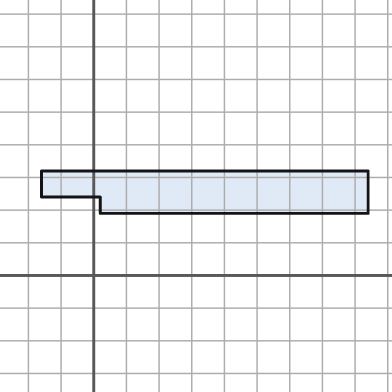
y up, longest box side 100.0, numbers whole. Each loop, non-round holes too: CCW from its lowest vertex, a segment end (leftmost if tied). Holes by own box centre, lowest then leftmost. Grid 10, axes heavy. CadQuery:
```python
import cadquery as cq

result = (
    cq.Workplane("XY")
    .moveTo(2.0, 19.0)
    .lineTo(84.0, 19.0)
    .lineTo(84.0, 32.0)
    .lineTo(-16.0, 32.0)
    .lineTo(-16.0, 24.0)
    .lineTo(2.0, 24.0)
    .close()
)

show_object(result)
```